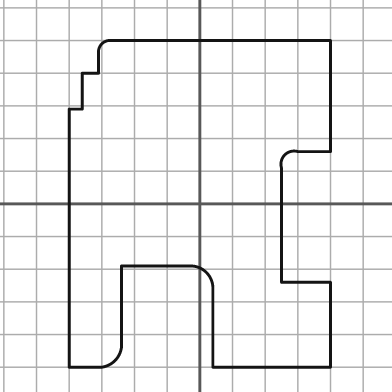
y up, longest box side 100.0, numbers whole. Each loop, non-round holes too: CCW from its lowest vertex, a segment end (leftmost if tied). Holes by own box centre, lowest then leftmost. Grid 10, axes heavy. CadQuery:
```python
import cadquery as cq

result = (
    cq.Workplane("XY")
    .moveTo(-40.0, -50.0)
    .lineTo(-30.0, -50.0)
    .threePointArc((-26.0, -48.0), (-24.0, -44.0))
    .lineTo(-24.0, -19.0)
    .lineTo(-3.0, -19.0)
    .threePointArc((2.0, -21.0), (4.0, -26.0))
    .lineTo(4.0, -50.0)
    .lineTo(40.0, -50.0)
    .lineTo(40.0, -24.0)
    .lineTo(25.0, -24.0)
    .lineTo(25.0, 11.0)
    .threePointArc((26.0, 15.0), (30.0, 16.0))
    .lineTo(40.0, 16.0)
    .lineTo(40.0, 50.0)
    .lineTo(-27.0, 50.0)
    .threePointArc((-30.0, 49.0), (-31.0, 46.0))
    .lineTo(-31.0, 40.0)
    .lineTo(-36.0, 40.0)
    .lineTo(-36.0, 29.0)
    .lineTo(-40.0, 29.0)
    .close()
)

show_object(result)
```